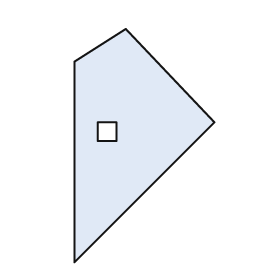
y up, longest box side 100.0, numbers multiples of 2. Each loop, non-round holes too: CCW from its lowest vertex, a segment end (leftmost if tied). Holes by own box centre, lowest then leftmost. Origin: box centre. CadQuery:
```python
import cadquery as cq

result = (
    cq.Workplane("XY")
    .moveTo(-30.0, -50.0)
    .lineTo(30.0, 10.0)
    .lineTo(-8.0, 50.0)
    .lineTo(-30.0, 36.0)
    .close()
    .moveTo(-20.0, 2.0)
    .lineTo(-12.0, 2.0)
    .lineTo(-12.0, 10.0)
    .lineTo(-20.0, 10.0)
    .close()
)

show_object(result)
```